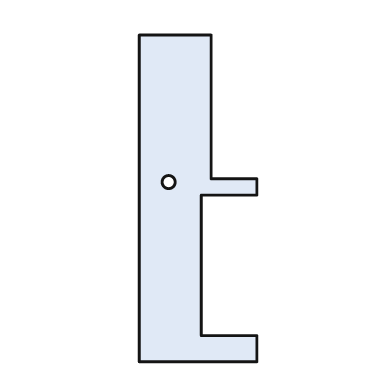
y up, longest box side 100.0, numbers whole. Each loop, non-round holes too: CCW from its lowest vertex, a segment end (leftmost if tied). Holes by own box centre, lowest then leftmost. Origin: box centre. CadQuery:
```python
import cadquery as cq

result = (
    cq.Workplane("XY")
    .moveTo(-18.0, -50.0)
    .lineTo(18.0, -50.0)
    .lineTo(18.0, -42.0)
    .lineTo(1.0, -42.0)
    .lineTo(1.0, 1.0)
    .lineTo(18.0, 1.0)
    .lineTo(18.0, 6.0)
    .lineTo(4.0, 6.0)
    .lineTo(4.0, 50.0)
    .lineTo(-18.0, 50.0)
    .close()
    .moveTo(-9.0, 5.0)
    .circle(2.0)
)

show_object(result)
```